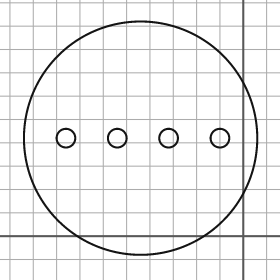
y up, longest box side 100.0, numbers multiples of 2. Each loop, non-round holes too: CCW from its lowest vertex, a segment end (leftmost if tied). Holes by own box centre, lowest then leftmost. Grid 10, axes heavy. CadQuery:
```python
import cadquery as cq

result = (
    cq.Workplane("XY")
    .moveTo(-44.0, 42.0)
    .circle(50.0)
    .moveTo(-76.0, 42.0)
    .circle(4.0)
    .moveTo(-54.0, 42.0)
    .circle(4.0)
    .moveTo(-32.0, 42.0)
    .circle(4.0)
    .moveTo(-10.0, 42.0)
    .circle(4.0)
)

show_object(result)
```